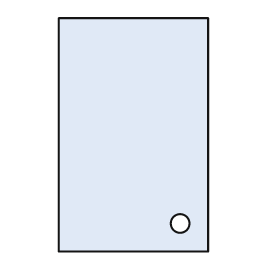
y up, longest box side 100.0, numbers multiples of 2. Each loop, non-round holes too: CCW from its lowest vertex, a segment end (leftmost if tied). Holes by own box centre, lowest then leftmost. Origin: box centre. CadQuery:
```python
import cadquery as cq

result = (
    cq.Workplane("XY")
    .moveTo(-32.0, -50.0)
    .lineTo(32.0, -50.0)
    .lineTo(32.0, 50.0)
    .lineTo(-32.0, 50.0)
    .close()
    .moveTo(20.0, -38.0)
    .circle(4.0)
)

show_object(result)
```